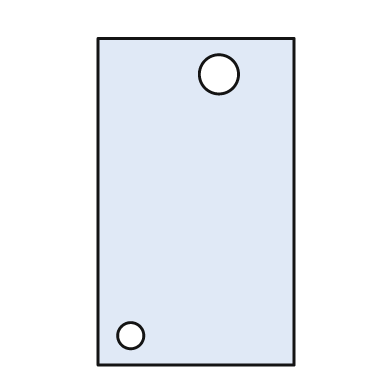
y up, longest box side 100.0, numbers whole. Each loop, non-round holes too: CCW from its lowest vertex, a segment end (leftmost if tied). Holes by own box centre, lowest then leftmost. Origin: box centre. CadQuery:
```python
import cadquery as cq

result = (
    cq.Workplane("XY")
    .moveTo(-30.0, -50.0)
    .lineTo(30.0, -50.0)
    .lineTo(30.0, 50.0)
    .lineTo(-30.0, 50.0)
    .close()
    .moveTo(-20.0, -41.0)
    .circle(4.0)
    .moveTo(7.0, 39.0)
    .circle(6.0)
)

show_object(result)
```